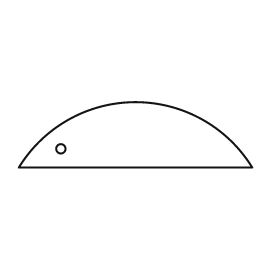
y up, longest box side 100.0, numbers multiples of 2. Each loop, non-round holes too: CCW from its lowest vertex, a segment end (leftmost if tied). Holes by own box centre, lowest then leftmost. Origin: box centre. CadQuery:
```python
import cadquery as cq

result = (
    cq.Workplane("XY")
    .moveTo(-50.0, -14.0)
    .lineTo(50.0, -14.0)
    .threePointArc((0.0, 14.0), (-50.0, -14.0))
    .close()
    .moveTo(-32.0, -6.0)
    .circle(2.0)
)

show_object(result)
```